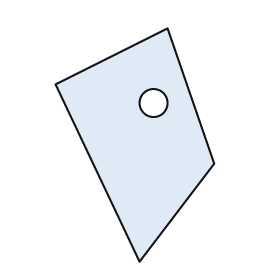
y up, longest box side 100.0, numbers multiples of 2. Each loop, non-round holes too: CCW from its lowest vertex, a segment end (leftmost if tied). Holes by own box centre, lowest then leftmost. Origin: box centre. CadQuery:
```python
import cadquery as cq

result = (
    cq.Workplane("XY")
    .moveTo(2.0, -50.0)
    .lineTo(34.0, -8.0)
    .lineTo(14.0, 50.0)
    .lineTo(-34.0, 26.0)
    .close()
    .moveTo(8.0, 18.0)
    .circle(6.0)
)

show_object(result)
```